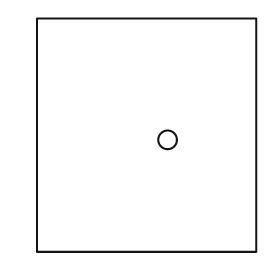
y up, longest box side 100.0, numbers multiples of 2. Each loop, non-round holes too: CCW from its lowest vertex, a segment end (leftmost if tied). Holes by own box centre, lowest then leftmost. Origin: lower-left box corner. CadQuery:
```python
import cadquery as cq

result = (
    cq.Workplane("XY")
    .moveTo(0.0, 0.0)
    .lineTo(94.0, 0.0)
    .lineTo(94.0, 100.0)
    .lineTo(0.0, 100.0)
    .close()
    .moveTo(56.0, 48.0)
    .circle(4.0)
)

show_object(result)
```